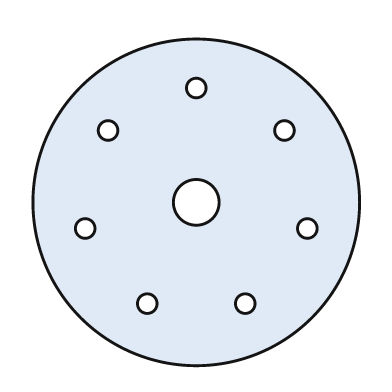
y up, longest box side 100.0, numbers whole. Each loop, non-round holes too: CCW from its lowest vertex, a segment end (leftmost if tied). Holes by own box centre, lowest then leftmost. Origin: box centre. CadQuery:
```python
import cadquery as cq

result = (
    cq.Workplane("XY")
    .moveTo(0.0, 0.0)
    .circle(50.0)
    .moveTo(-15.0, -31.0)
    .circle(3.0)
    .moveTo(15.0, -31.0)
    .circle(3.0)
    .moveTo(-34.0, -8.0)
    .circle(3.0)
    .moveTo(34.0, -8.0)
    .circle(3.0)
    .moveTo(0.0, 0.0)
    .circle(7.0)
    .moveTo(-27.0, 22.0)
    .circle(3.0)
    .moveTo(27.0, 22.0)
    .circle(3.0)
    .moveTo(0.0, 35.0)
    .circle(3.0)
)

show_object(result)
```